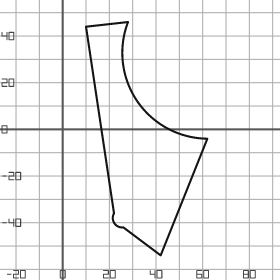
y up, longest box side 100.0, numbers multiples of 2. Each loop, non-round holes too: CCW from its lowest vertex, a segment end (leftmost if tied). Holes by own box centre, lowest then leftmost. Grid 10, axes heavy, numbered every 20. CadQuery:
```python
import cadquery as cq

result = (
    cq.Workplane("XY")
    .moveTo(42.0, -54.0)
    .lineTo(62.0, -4.0)
    .threePointArc((32.0, 12.0), (28.0, 46.0))
    .lineTo(10.0, 44.0)
    .lineTo(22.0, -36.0)
    .threePointArc((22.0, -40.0), (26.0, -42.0))
    .close()
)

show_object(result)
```